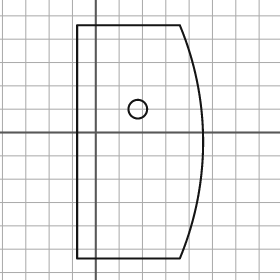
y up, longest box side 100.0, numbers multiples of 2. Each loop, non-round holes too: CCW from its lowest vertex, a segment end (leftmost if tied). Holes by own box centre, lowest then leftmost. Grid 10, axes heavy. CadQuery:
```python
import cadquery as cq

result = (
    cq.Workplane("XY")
    .moveTo(-8.0, -54.0)
    .lineTo(36.0, -54.0)
    .threePointArc((46.0, -4.0), (36.0, 46.0))
    .lineTo(-8.0, 46.0)
    .close()
    .moveTo(18.0, 10.0)
    .circle(4.0)
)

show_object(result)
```